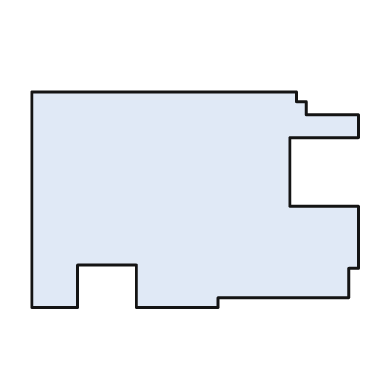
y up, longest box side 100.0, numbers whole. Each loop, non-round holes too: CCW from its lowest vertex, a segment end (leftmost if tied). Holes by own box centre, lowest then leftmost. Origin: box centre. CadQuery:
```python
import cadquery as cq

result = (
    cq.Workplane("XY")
    .moveTo(-50.0, -33.0)
    .lineTo(-36.0, -33.0)
    .lineTo(-36.0, -20.0)
    .lineTo(-18.0, -20.0)
    .lineTo(-18.0, -33.0)
    .lineTo(7.0, -33.0)
    .lineTo(7.0, -30.0)
    .lineTo(47.0, -30.0)
    .lineTo(47.0, -21.0)
    .lineTo(50.0, -21.0)
    .lineTo(50.0, -2.0)
    .lineTo(29.0, -2.0)
    .lineTo(29.0, 19.0)
    .lineTo(50.0, 19.0)
    .lineTo(50.0, 26.0)
    .lineTo(34.0, 26.0)
    .lineTo(34.0, 30.0)
    .lineTo(31.0, 30.0)
    .lineTo(31.0, 33.0)
    .lineTo(-50.0, 33.0)
    .close()
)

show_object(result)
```